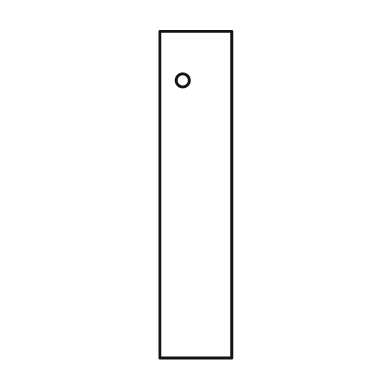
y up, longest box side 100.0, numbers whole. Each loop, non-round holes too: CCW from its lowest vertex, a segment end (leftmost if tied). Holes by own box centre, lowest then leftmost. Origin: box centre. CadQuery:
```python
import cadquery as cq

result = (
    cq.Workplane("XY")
    .moveTo(-11.0, -50.0)
    .lineTo(11.0, -50.0)
    .lineTo(11.0, 50.0)
    .lineTo(-11.0, 50.0)
    .close()
    .moveTo(-4.0, 35.0)
    .circle(2.0)
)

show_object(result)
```